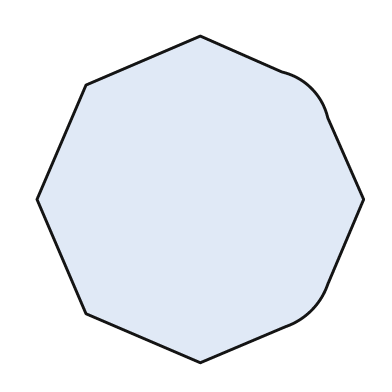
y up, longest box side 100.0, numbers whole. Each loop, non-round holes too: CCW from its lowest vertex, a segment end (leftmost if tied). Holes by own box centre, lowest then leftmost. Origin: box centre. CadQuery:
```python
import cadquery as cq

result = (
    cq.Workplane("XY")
    .moveTo(0.0, -50.0)
    .lineTo(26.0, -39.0)
    .threePointArc((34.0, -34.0), (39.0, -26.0))
    .lineTo(50.0, 0.0)
    .lineTo(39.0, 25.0)
    .threePointArc((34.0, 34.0), (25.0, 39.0))
    .lineTo(0.0, 50.0)
    .lineTo(-35.0, 35.0)
    .lineTo(-50.0, 0.0)
    .lineTo(-35.0, -35.0)
    .close()
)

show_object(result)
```